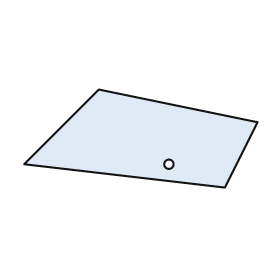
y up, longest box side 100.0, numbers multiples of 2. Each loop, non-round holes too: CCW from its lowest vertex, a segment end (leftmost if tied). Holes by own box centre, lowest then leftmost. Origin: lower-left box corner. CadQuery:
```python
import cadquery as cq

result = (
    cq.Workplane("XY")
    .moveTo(86.0, 0.0)
    .lineTo(100.0, 28.0)
    .lineTo(32.0, 42.0)
    .lineTo(0.0, 10.0)
    .close()
    .moveTo(62.0, 10.0)
    .circle(2.0)
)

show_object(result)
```